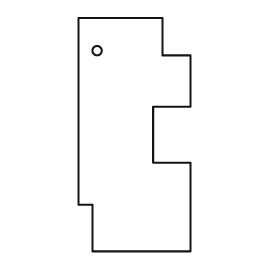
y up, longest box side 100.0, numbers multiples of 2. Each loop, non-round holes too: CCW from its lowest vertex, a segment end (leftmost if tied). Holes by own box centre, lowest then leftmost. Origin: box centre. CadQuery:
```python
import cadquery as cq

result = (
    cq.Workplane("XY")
    .moveTo(-18.0, -50.0)
    .lineTo(24.0, -50.0)
    .lineTo(24.0, -12.0)
    .lineTo(8.0, -12.0)
    .lineTo(8.0, 12.0)
    .lineTo(24.0, 12.0)
    .lineTo(24.0, 34.0)
    .lineTo(12.0, 34.0)
    .lineTo(12.0, 50.0)
    .lineTo(-24.0, 50.0)
    .lineTo(-24.0, -30.0)
    .lineTo(-18.0, -30.0)
    .close()
    .moveTo(-16.0, 36.0)
    .circle(2.0)
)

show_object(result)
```